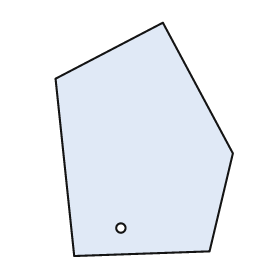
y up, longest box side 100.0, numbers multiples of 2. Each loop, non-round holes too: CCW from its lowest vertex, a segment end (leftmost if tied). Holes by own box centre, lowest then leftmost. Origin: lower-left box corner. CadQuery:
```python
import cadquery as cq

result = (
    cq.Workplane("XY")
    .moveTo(8.0, 0.0)
    .lineTo(66.0, 2.0)
    .lineTo(76.0, 44.0)
    .lineTo(46.0, 100.0)
    .lineTo(0.0, 76.0)
    .close()
    .moveTo(28.0, 12.0)
    .circle(2.0)
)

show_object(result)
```